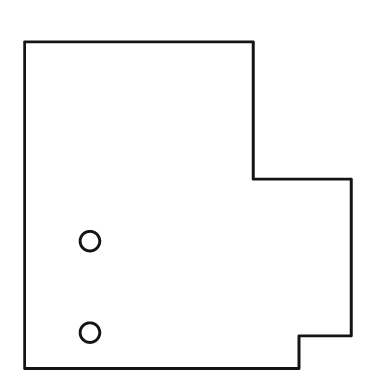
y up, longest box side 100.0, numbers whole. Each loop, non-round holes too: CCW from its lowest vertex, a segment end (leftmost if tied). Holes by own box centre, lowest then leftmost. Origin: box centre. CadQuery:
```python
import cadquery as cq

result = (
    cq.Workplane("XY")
    .moveTo(-50.0, -50.0)
    .lineTo(34.0, -50.0)
    .lineTo(34.0, -40.0)
    .lineTo(50.0, -40.0)
    .lineTo(50.0, 8.0)
    .lineTo(20.0, 8.0)
    .lineTo(20.0, 50.0)
    .lineTo(-50.0, 50.0)
    .close()
    .moveTo(-30.0, -39.0)
    .circle(3.0)
    .moveTo(-30.0, -11.0)
    .circle(3.0)
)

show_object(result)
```